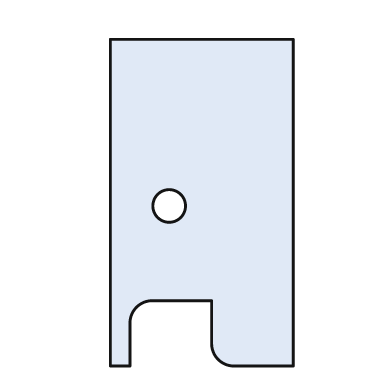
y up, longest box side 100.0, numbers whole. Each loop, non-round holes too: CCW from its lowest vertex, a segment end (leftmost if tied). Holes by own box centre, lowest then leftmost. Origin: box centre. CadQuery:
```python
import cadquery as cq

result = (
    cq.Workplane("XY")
    .moveTo(-28.0, -50.0)
    .lineTo(-22.0, -50.0)
    .lineTo(-22.0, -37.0)
    .threePointArc((-20.0, -32.0), (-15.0, -30.0))
    .lineTo(3.0, -30.0)
    .lineTo(3.0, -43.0)
    .threePointArc((5.0, -48.0), (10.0, -50.0))
    .lineTo(28.0, -50.0)
    .lineTo(28.0, 50.0)
    .lineTo(-28.0, 50.0)
    .close()
    .moveTo(-10.0, -1.0)
    .circle(5.0)
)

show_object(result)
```